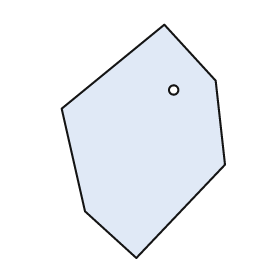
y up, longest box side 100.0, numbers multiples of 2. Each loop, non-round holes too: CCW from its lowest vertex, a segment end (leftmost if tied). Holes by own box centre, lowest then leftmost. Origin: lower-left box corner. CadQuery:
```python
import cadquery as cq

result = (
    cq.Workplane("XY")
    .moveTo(32.0, 0.0)
    .lineTo(70.0, 40.0)
    .lineTo(66.0, 76.0)
    .lineTo(44.0, 100.0)
    .lineTo(0.0, 64.0)
    .lineTo(10.0, 20.0)
    .close()
    .moveTo(48.0, 72.0)
    .circle(2.0)
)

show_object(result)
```